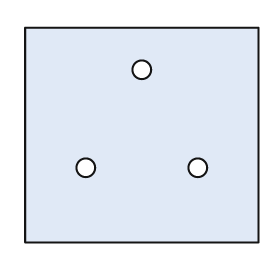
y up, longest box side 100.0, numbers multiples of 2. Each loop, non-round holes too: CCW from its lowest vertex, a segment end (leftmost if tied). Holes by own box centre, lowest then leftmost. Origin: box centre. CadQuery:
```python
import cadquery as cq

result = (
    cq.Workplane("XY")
    .moveTo(-50.0, -46.0)
    .lineTo(50.0, -46.0)
    .lineTo(50.0, 46.0)
    .lineTo(-50.0, 46.0)
    .close()
    .moveTo(-24.0, -14.0)
    .circle(4.0)
    .moveTo(24.0, -14.0)
    .circle(4.0)
    .moveTo(0.0, 28.0)
    .circle(4.0)
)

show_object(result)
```